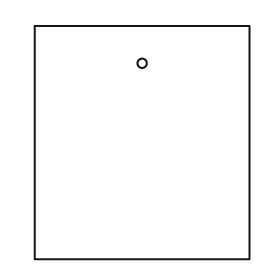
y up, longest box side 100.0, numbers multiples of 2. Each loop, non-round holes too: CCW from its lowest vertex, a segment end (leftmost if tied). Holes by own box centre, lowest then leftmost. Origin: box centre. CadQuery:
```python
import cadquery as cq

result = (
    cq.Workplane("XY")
    .moveTo(-46.0, -50.0)
    .lineTo(46.0, -50.0)
    .lineTo(46.0, 50.0)
    .lineTo(-46.0, 50.0)
    .close()
    .moveTo(0.0, 34.0)
    .circle(2.0)
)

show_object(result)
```